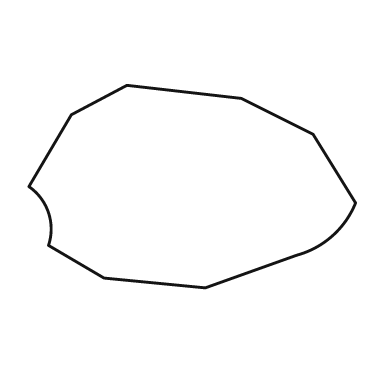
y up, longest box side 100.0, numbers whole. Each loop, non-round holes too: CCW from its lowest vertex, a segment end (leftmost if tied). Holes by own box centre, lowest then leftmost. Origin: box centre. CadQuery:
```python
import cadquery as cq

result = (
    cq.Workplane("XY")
    .moveTo(4.0, -31.0)
    .lineTo(32.0, -21.0)
    .threePointArc((43.0, -15.0), (50.0, -5.0))
    .lineTo(37.0, 16.0)
    .lineTo(15.0, 27.0)
    .lineTo(-20.0, 31.0)
    .lineTo(-37.0, 22.0)
    .lineTo(-50.0, 0.0)
    .threePointArc((-44.0, -8.0), (-44.0, -18.0))
    .lineTo(-27.0, -28.0)
    .close()
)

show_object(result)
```